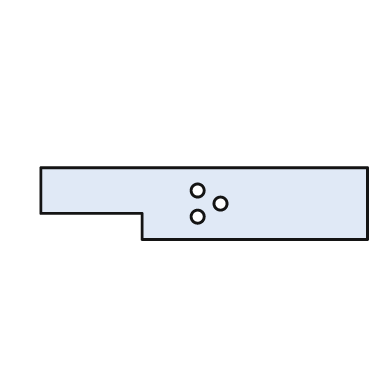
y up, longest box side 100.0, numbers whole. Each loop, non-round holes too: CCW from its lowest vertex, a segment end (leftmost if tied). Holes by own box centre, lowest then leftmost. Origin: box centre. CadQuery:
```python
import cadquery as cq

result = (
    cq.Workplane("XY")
    .moveTo(-19.0, -11.0)
    .lineTo(50.0, -11.0)
    .lineTo(50.0, 11.0)
    .lineTo(-50.0, 11.0)
    .lineTo(-50.0, -3.0)
    .lineTo(-19.0, -3.0)
    .close()
    .moveTo(-2.0, -4.0)
    .circle(2.0)
    .moveTo(5.0, 0.0)
    .circle(2.0)
    .moveTo(-2.0, 4.0)
    .circle(2.0)
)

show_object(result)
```